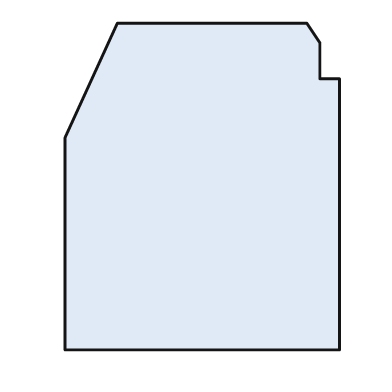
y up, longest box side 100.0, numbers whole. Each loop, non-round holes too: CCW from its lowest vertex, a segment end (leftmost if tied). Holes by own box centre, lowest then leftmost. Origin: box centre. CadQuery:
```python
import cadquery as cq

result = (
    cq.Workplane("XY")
    .moveTo(-42.0, -50.0)
    .lineTo(42.0, -50.0)
    .lineTo(42.0, 33.0)
    .lineTo(36.0, 33.0)
    .lineTo(36.0, 44.0)
    .lineTo(32.0, 50.0)
    .lineTo(-26.0, 50.0)
    .lineTo(-42.0, 15.0)
    .close()
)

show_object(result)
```